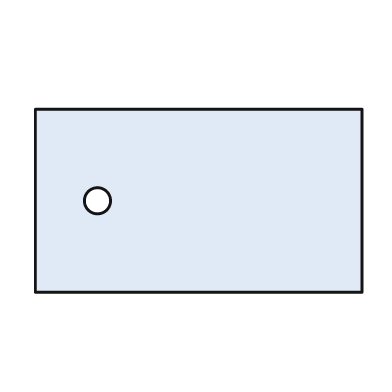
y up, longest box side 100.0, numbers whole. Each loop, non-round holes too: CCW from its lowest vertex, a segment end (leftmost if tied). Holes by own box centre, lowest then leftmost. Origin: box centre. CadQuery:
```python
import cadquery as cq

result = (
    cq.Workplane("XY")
    .moveTo(-50.0, -28.0)
    .lineTo(50.0, -28.0)
    .lineTo(50.0, 28.0)
    .lineTo(-50.0, 28.0)
    .close()
    .moveTo(-31.0, 0.0)
    .circle(4.0)
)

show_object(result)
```